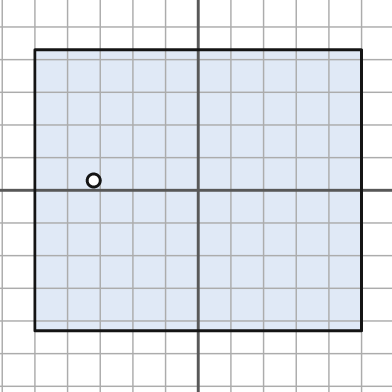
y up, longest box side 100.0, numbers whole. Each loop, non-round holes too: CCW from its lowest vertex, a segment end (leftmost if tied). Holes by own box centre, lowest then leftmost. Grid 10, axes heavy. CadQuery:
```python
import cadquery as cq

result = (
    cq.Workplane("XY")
    .moveTo(-50.0, -43.0)
    .lineTo(50.0, -43.0)
    .lineTo(50.0, 43.0)
    .lineTo(-50.0, 43.0)
    .close()
    .moveTo(-32.0, 3.0)
    .circle(2.0)
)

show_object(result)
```